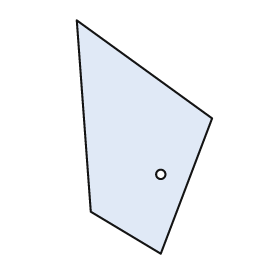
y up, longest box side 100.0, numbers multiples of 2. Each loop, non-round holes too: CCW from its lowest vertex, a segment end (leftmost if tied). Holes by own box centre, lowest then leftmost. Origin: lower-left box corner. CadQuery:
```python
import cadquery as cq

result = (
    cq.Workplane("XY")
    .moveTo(36.0, 0.0)
    .lineTo(58.0, 58.0)
    .lineTo(0.0, 100.0)
    .lineTo(6.0, 18.0)
    .close()
    .moveTo(36.0, 34.0)
    .circle(2.0)
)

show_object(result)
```